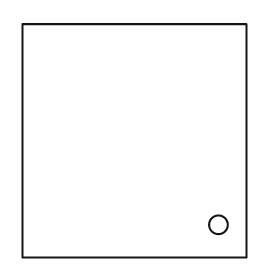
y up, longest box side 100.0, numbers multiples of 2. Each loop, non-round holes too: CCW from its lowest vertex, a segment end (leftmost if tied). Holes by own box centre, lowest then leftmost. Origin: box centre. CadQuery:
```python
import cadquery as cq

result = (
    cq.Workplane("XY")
    .moveTo(-48.0, -50.0)
    .lineTo(48.0, -50.0)
    .lineTo(48.0, 50.0)
    .lineTo(-48.0, 50.0)
    .close()
    .moveTo(36.0, -36.0)
    .circle(4.0)
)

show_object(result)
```